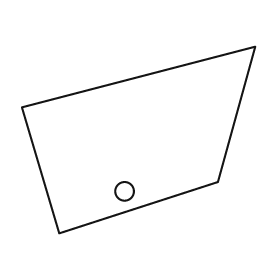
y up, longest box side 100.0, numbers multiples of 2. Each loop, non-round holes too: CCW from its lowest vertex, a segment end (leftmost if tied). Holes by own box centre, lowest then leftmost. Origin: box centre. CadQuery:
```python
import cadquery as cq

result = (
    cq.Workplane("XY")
    .moveTo(-34.0, -40.0)
    .lineTo(34.0, -18.0)
    .lineTo(50.0, 40.0)
    .lineTo(-50.0, 14.0)
    .close()
    .moveTo(-6.0, -22.0)
    .circle(4.0)
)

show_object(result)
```